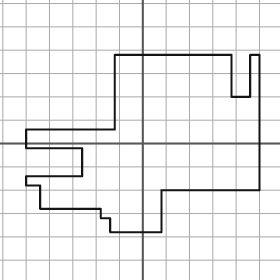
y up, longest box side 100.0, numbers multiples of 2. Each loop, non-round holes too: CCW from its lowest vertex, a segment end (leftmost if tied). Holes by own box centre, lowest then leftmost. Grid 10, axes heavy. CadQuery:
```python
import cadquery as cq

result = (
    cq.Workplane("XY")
    .moveTo(-14.0, -38.0)
    .lineTo(8.0, -38.0)
    .lineTo(8.0, -20.0)
    .lineTo(50.0, -20.0)
    .lineTo(50.0, 38.0)
    .lineTo(46.0, 38.0)
    .lineTo(46.0, 20.0)
    .lineTo(38.0, 20.0)
    .lineTo(38.0, 38.0)
    .lineTo(-12.0, 38.0)
    .lineTo(-12.0, 6.0)
    .lineTo(-50.0, 6.0)
    .lineTo(-50.0, -2.0)
    .lineTo(-26.0, -2.0)
    .lineTo(-26.0, -14.0)
    .lineTo(-50.0, -14.0)
    .lineTo(-50.0, -18.0)
    .lineTo(-44.0, -18.0)
    .lineTo(-44.0, -28.0)
    .lineTo(-18.0, -28.0)
    .lineTo(-18.0, -32.0)
    .lineTo(-14.0, -32.0)
    .close()
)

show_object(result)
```